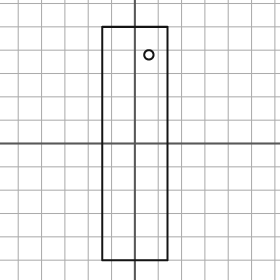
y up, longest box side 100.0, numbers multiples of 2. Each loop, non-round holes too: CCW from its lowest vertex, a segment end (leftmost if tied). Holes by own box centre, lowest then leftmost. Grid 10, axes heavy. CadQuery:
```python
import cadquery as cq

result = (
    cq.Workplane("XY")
    .moveTo(-14.0, -50.0)
    .lineTo(14.0, -50.0)
    .lineTo(14.0, 50.0)
    .lineTo(-14.0, 50.0)
    .close()
    .moveTo(6.0, 38.0)
    .circle(2.0)
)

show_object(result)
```